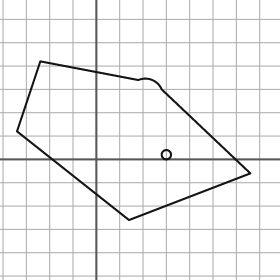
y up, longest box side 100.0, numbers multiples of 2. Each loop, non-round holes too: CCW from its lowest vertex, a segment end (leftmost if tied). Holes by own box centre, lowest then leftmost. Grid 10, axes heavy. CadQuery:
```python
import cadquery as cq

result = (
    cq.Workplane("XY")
    .moveTo(14.0, -26.0)
    .lineTo(66.0, -6.0)
    .lineTo(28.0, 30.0)
    .threePointArc((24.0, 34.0), (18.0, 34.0))
    .lineTo(-24.0, 42.0)
    .lineTo(-34.0, 12.0)
    .close()
    .moveTo(30.0, 2.0)
    .circle(2.0)
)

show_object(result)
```